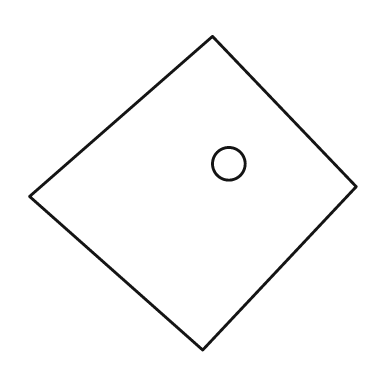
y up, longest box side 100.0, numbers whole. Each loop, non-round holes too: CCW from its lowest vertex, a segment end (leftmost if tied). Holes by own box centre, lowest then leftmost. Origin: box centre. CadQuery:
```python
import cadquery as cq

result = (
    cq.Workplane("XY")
    .moveTo(3.0, -48.0)
    .lineTo(50.0, 2.0)
    .lineTo(6.0, 48.0)
    .lineTo(-50.0, -1.0)
    .close()
    .moveTo(11.0, 9.0)
    .circle(5.0)
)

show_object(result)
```